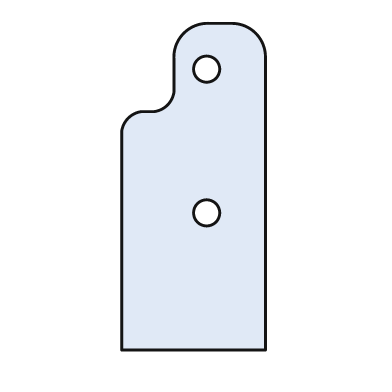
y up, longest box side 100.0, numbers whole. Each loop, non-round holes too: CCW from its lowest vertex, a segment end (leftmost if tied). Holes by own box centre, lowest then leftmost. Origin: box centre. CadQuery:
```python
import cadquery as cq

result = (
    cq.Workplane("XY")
    .moveTo(-22.0, -50.0)
    .lineTo(22.0, -50.0)
    .lineTo(22.0, 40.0)
    .threePointArc((19.0, 47.0), (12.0, 50.0))
    .lineTo(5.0, 50.0)
    .threePointArc((-3.0, 47.0), (-6.0, 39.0))
    .lineTo(-6.0, 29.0)
    .threePointArc((-8.0, 25.0), (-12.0, 23.0))
    .lineTo(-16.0, 23.0)
    .threePointArc((-20.0, 21.0), (-22.0, 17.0))
    .close()
    .moveTo(4.0, -8.0)
    .circle(4.0)
    .moveTo(4.0, 36.0)
    .circle(4.0)
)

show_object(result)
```